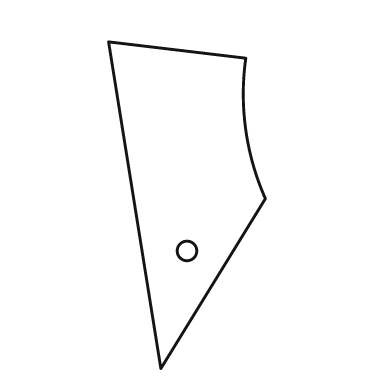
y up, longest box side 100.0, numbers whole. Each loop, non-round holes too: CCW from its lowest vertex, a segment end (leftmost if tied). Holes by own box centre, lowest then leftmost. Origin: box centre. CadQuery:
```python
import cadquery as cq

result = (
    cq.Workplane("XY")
    .moveTo(-8.0, -50.0)
    .lineTo(24.0, 2.0)
    .threePointArc((18.0, 23.0), (18.0, 45.0))
    .lineTo(-24.0, 50.0)
    .close()
    .moveTo(0.0, -14.0)
    .circle(3.0)
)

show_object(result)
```